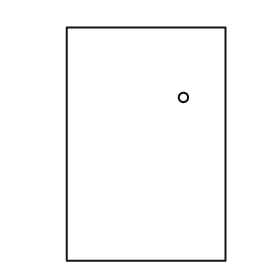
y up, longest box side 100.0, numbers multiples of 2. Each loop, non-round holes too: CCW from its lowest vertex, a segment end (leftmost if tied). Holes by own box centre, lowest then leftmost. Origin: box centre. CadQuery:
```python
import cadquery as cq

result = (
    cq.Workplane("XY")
    .moveTo(-34.0, -50.0)
    .lineTo(34.0, -50.0)
    .lineTo(34.0, 50.0)
    .lineTo(-34.0, 50.0)
    .close()
    .moveTo(16.0, 20.0)
    .circle(2.0)
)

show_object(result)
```